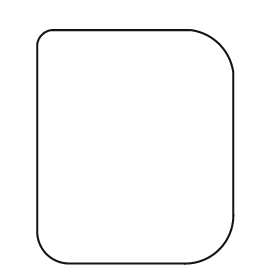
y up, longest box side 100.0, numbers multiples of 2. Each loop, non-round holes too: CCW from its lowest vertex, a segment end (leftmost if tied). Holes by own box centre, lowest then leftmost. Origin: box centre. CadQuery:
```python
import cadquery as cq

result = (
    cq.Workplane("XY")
    .moveTo(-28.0, -50.0)
    .lineTo(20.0, -50.0)
    .threePointArc((36.0, -44.0), (42.0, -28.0))
    .lineTo(42.0, 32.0)
    .threePointArc((36.0, 44.0), (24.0, 50.0))
    .lineTo(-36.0, 50.0)
    .threePointArc((-40.0, 48.0), (-42.0, 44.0))
    .lineTo(-42.0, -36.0)
    .threePointArc((-38.0, -46.0), (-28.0, -50.0))
    .close()
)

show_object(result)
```